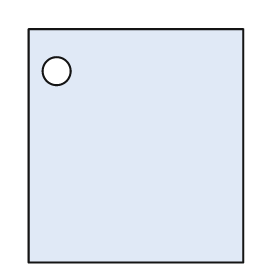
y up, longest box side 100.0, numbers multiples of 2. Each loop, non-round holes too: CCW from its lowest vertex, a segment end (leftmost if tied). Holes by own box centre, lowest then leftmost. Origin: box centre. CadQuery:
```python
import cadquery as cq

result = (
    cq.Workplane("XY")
    .moveTo(-46.0, -50.0)
    .lineTo(46.0, -50.0)
    .lineTo(46.0, 50.0)
    .lineTo(-46.0, 50.0)
    .close()
    .moveTo(-34.0, 32.0)
    .circle(6.0)
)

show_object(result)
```